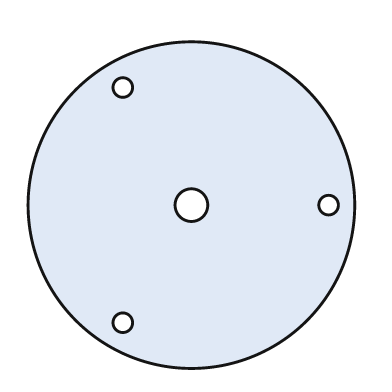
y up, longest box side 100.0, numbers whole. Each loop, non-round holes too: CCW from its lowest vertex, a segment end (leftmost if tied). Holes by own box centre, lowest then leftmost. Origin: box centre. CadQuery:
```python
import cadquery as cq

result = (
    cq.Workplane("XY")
    .moveTo(0.0, 0.0)
    .circle(50.0)
    .moveTo(-21.0, -36.0)
    .circle(3.0)
    .moveTo(0.0, 0.0)
    .circle(5.0)
    .moveTo(42.0, 0.0)
    .circle(3.0)
    .moveTo(-21.0, 36.0)
    .circle(3.0)
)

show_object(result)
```